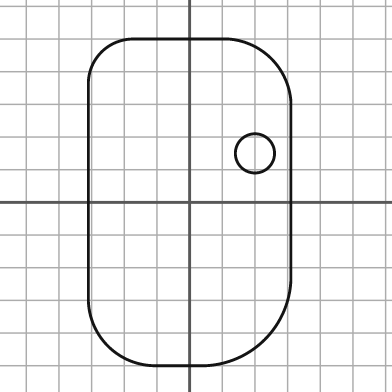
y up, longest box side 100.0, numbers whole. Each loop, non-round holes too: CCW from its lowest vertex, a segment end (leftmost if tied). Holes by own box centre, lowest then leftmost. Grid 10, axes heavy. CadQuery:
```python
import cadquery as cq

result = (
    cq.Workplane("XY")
    .moveTo(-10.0, -50.0)
    .lineTo(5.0, -50.0)
    .threePointArc((23.0, -42.0), (31.0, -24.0))
    .lineTo(31.0, 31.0)
    .threePointArc((25.0, 44.0), (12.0, 50.0))
    .lineTo(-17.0, 50.0)
    .threePointArc((-27.0, 46.0), (-31.0, 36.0))
    .lineTo(-31.0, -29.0)
    .threePointArc((-25.0, -44.0), (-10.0, -50.0))
    .close()
    .moveTo(20.0, 15.0)
    .circle(6.0)
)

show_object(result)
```